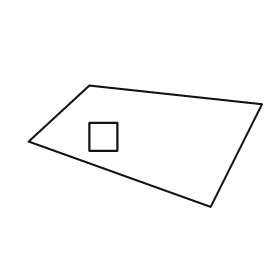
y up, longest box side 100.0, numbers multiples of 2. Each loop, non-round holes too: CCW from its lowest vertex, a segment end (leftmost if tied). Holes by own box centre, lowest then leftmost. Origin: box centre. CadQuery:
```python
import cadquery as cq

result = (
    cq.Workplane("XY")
    .moveTo(28.0, -26.0)
    .lineTo(50.0, 18.0)
    .lineTo(-24.0, 26.0)
    .lineTo(-50.0, 2.0)
    .close()
    .moveTo(-24.0, -2.0)
    .lineTo(-12.0, -2.0)
    .lineTo(-12.0, 10.0)
    .lineTo(-24.0, 10.0)
    .close()
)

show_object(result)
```